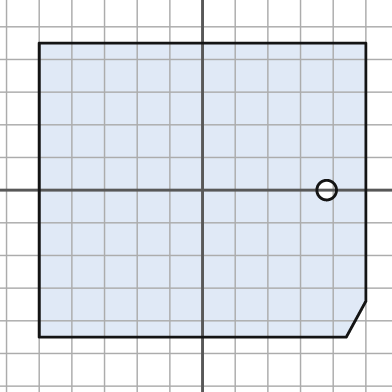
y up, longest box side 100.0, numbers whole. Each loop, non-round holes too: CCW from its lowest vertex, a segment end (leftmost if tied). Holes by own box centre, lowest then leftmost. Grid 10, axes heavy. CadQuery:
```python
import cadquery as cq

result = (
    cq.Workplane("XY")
    .moveTo(-50.0, -45.0)
    .lineTo(44.0, -45.0)
    .lineTo(50.0, -34.0)
    .lineTo(50.0, 45.0)
    .lineTo(-50.0, 45.0)
    .close()
    .moveTo(38.0, 0.0)
    .circle(3.0)
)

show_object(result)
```